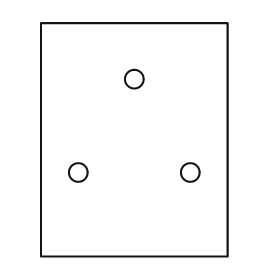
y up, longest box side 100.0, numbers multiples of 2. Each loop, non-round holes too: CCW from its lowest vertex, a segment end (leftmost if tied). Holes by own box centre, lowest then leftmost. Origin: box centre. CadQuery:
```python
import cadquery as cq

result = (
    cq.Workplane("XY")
    .moveTo(-40.0, -50.0)
    .lineTo(40.0, -50.0)
    .lineTo(40.0, 50.0)
    .lineTo(-40.0, 50.0)
    .close()
    .moveTo(-24.0, -14.0)
    .circle(4.0)
    .moveTo(24.0, -14.0)
    .circle(4.0)
    .moveTo(0.0, 26.0)
    .circle(4.0)
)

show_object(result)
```